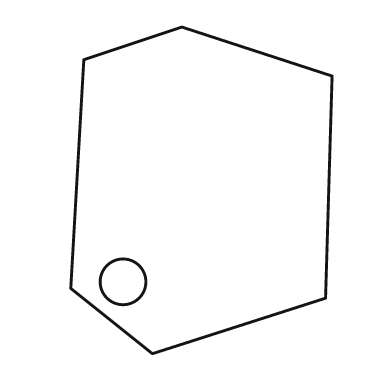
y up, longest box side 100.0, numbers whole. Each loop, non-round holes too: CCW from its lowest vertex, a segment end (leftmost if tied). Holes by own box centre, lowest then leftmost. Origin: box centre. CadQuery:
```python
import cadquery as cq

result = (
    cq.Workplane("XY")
    .moveTo(-15.0, -50.0)
    .lineTo(38.0, -33.0)
    .lineTo(40.0, 35.0)
    .lineTo(-6.0, 50.0)
    .lineTo(-36.0, 40.0)
    .lineTo(-40.0, -30.0)
    .close()
    .moveTo(-24.0, -28.0)
    .circle(7.0)
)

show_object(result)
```